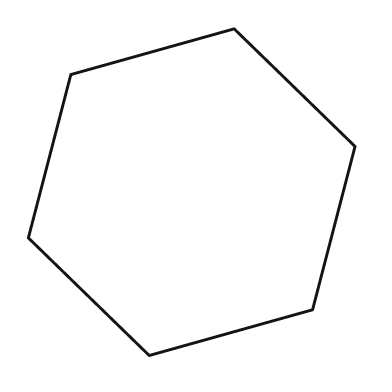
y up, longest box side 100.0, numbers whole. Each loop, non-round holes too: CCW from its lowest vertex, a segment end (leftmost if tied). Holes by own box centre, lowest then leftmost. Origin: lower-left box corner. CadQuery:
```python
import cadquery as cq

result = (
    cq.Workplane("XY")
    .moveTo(37.0, 0.0)
    .lineTo(87.0, 14.0)
    .lineTo(100.0, 64.0)
    .lineTo(63.0, 100.0)
    .lineTo(13.0, 86.0)
    .lineTo(0.0, 36.0)
    .close()
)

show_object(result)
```